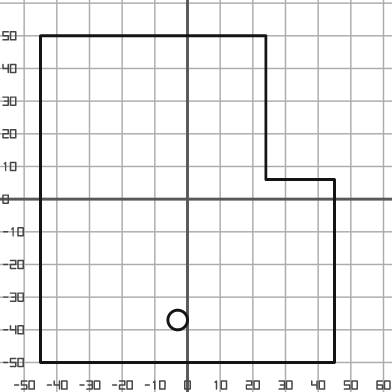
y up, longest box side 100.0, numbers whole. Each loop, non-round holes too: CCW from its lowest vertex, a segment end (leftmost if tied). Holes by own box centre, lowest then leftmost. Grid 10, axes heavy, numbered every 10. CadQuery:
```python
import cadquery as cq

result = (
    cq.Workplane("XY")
    .moveTo(-45.0, -50.0)
    .lineTo(45.0, -50.0)
    .lineTo(45.0, 6.0)
    .lineTo(24.0, 6.0)
    .lineTo(24.0, 50.0)
    .lineTo(-45.0, 50.0)
    .close()
    .moveTo(-3.0, -37.0)
    .circle(3.0)
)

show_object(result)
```